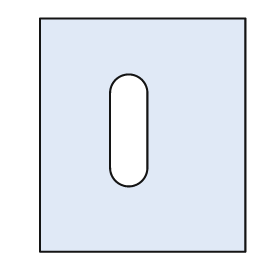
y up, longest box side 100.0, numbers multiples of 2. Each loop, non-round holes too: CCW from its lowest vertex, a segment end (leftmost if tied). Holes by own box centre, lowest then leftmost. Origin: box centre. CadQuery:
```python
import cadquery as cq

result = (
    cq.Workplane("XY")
    .moveTo(-44.0, -50.0)
    .lineTo(44.0, -50.0)
    .lineTo(44.0, 50.0)
    .lineTo(-44.0, 50.0)
    .close()
    .moveTo(-14.0, -14.0)
    .threePointArc((-6.0, -22.0), (2.0, -14.0))
    .lineTo(2.0, 18.0)
    .threePointArc((-6.0, 26.0), (-14.0, 18.0))
    .close()
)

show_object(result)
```